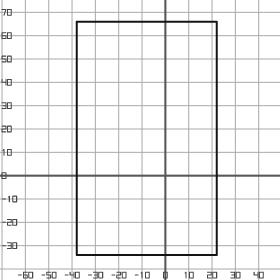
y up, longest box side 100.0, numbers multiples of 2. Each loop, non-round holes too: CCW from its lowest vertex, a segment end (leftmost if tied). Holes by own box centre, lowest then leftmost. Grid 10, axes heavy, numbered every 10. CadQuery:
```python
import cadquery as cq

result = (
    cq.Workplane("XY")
    .moveTo(-38.0, -34.0)
    .lineTo(22.0, -34.0)
    .lineTo(22.0, 66.0)
    .lineTo(-38.0, 66.0)
    .close()
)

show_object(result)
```